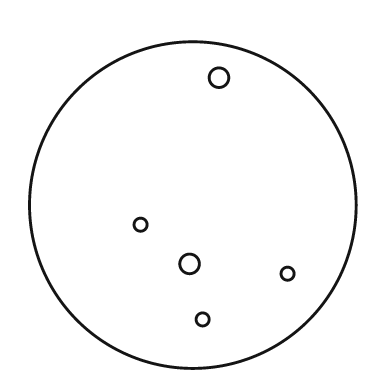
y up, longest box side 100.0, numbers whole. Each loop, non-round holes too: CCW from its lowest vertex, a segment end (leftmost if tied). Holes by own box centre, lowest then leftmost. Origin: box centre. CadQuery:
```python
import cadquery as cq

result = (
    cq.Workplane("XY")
    .moveTo(0.0, 0.0)
    .circle(50.0)
    .moveTo(3.0, -35.0)
    .circle(2.0)
    .moveTo(29.0, -21.0)
    .circle(2.0)
    .moveTo(-1.0, -18.0)
    .circle(3.0)
    .moveTo(-16.0, -6.0)
    .circle(2.0)
    .moveTo(8.0, 39.0)
    .circle(3.0)
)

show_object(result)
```